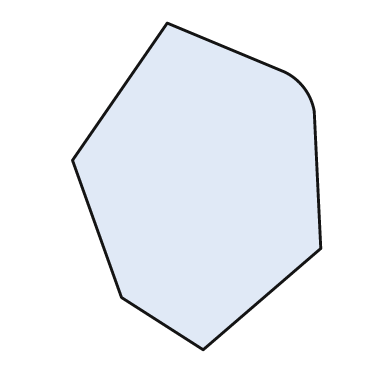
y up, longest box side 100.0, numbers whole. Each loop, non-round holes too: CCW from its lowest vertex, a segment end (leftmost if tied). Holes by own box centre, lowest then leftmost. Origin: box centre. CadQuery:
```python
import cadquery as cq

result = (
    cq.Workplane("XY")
    .moveTo(2.0, -50.0)
    .lineTo(38.0, -19.0)
    .lineTo(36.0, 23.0)
    .threePointArc((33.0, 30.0), (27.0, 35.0))
    .lineTo(-9.0, 50.0)
    .lineTo(-38.0, 8.0)
    .lineTo(-23.0, -34.0)
    .close()
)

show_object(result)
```